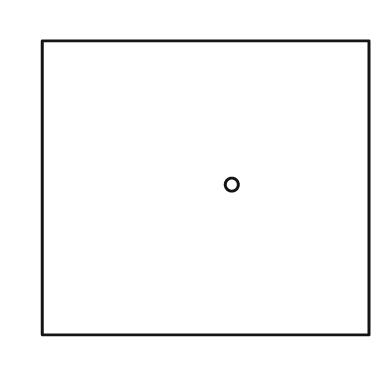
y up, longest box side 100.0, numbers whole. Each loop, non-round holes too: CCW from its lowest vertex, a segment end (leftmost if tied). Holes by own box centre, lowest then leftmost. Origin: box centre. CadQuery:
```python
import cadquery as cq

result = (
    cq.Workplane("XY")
    .moveTo(-50.0, -45.0)
    .lineTo(50.0, -45.0)
    .lineTo(50.0, 45.0)
    .lineTo(-50.0, 45.0)
    .close()
    .moveTo(8.0, 1.0)
    .circle(2.0)
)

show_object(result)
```